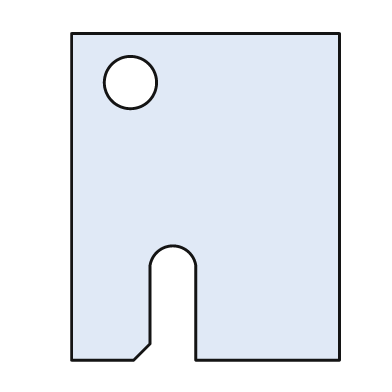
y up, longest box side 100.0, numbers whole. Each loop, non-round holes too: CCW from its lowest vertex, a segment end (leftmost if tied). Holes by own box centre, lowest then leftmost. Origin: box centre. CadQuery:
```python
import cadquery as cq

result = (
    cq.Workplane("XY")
    .moveTo(-41.0, -50.0)
    .lineTo(-22.0, -50.0)
    .lineTo(-17.0, -45.0)
    .lineTo(-17.0, -21.0)
    .threePointArc((-10.0, -15.0), (-3.0, -21.0))
    .lineTo(-3.0, -50.0)
    .lineTo(41.0, -50.0)
    .lineTo(41.0, 50.0)
    .lineTo(-41.0, 50.0)
    .close()
    .moveTo(-23.0, 35.0)
    .circle(8.0)
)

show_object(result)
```